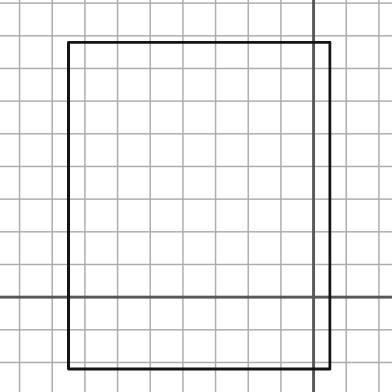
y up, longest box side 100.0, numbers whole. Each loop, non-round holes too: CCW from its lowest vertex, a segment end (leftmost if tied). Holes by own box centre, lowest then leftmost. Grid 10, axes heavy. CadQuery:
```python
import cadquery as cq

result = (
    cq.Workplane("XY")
    .moveTo(-75.0, -22.0)
    .lineTo(5.0, -22.0)
    .lineTo(5.0, 78.0)
    .lineTo(-75.0, 78.0)
    .close()
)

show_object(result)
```